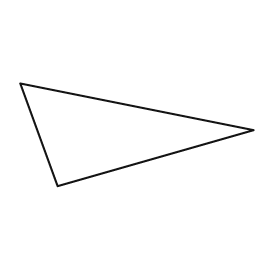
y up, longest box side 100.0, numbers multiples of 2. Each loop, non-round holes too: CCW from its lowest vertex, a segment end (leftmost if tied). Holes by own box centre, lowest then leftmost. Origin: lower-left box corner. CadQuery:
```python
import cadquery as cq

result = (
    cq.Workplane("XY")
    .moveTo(16.0, 0.0)
    .lineTo(100.0, 24.0)
    .lineTo(0.0, 44.0)
    .close()
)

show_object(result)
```